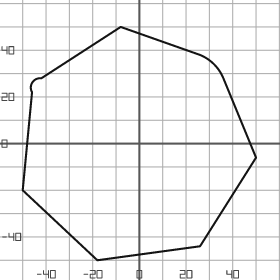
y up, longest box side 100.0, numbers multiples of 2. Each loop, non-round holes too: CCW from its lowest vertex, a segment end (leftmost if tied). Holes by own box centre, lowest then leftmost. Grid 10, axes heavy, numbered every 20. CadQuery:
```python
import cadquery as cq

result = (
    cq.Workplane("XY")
    .moveTo(-18.0, -50.0)
    .lineTo(26.0, -44.0)
    .lineTo(50.0, -6.0)
    .lineTo(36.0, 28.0)
    .threePointArc((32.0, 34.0), (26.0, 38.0))
    .lineTo(-8.0, 50.0)
    .lineTo(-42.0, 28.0)
    .threePointArc((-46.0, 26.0), (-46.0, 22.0))
    .lineTo(-50.0, -20.0)
    .close()
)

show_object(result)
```